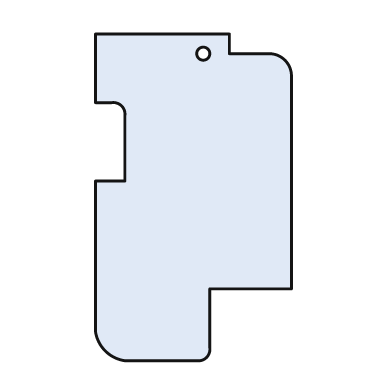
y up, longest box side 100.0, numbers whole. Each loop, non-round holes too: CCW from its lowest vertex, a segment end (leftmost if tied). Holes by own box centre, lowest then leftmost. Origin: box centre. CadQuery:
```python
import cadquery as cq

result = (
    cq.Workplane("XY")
    .moveTo(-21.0, -50.0)
    .lineTo(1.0, -50.0)
    .threePointArc((4.0, -49.0), (5.0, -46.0))
    .lineTo(5.0, -28.0)
    .lineTo(30.0, -28.0)
    .lineTo(30.0, 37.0)
    .threePointArc((28.0, 42.0), (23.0, 44.0))
    .lineTo(11.0, 44.0)
    .lineTo(11.0, 50.0)
    .lineTo(-30.0, 50.0)
    .lineTo(-30.0, 29.0)
    .lineTo(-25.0, 29.0)
    .threePointArc((-22.0, 28.0), (-21.0, 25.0))
    .lineTo(-21.0, 5.0)
    .lineTo(-30.0, 5.0)
    .lineTo(-30.0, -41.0)
    .threePointArc((-27.0, -47.0), (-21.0, -50.0))
    .close()
    .moveTo(3.0, 44.0)
    .circle(2.0)
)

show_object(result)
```